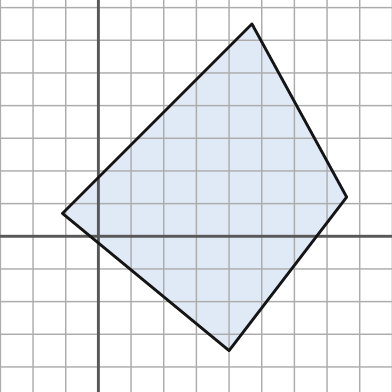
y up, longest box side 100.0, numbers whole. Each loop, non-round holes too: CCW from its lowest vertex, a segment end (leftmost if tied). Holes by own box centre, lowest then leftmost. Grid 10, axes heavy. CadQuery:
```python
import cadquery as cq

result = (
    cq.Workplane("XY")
    .moveTo(40.0, -35.0)
    .lineTo(76.0, 12.0)
    .lineTo(47.0, 65.0)
    .lineTo(-11.0, 7.0)
    .close()
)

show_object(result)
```